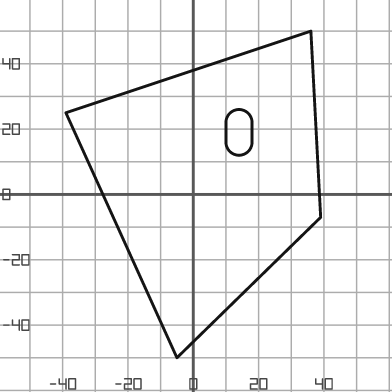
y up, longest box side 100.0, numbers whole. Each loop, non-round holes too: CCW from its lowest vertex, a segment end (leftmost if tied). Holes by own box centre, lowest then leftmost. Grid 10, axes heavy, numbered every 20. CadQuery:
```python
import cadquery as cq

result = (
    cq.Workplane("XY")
    .moveTo(-5.0, -50.0)
    .lineTo(39.0, -7.0)
    .lineTo(36.0, 50.0)
    .lineTo(-39.0, 25.0)
    .close()
    .moveTo(10.0, 16.0)
    .threePointArc((14.0, 12.0), (18.0, 16.0))
    .lineTo(18.0, 22.0)
    .threePointArc((14.0, 26.0), (10.0, 22.0))
    .close()
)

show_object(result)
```